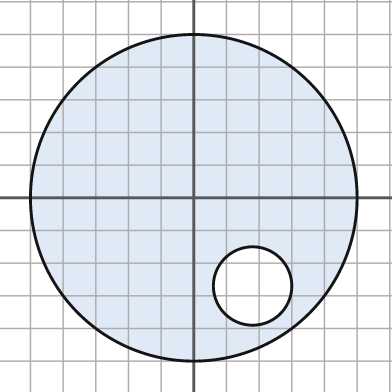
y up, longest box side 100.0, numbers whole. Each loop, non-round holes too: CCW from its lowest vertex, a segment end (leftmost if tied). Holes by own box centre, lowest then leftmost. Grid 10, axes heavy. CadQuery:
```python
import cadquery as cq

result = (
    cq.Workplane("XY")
    .moveTo(0.0, 0.0)
    .circle(50.0)
    .moveTo(18.0, -27.0)
    .circle(12.0)
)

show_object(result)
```